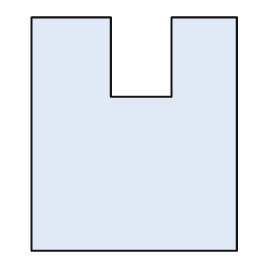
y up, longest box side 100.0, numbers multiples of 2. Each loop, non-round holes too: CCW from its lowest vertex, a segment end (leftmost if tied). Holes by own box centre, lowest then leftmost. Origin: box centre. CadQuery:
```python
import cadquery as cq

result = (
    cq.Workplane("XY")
    .moveTo(-44.0, -50.0)
    .lineTo(44.0, -50.0)
    .lineTo(44.0, 50.0)
    .lineTo(16.0, 50.0)
    .lineTo(16.0, 16.0)
    .lineTo(-10.0, 16.0)
    .lineTo(-10.0, 50.0)
    .lineTo(-44.0, 50.0)
    .close()
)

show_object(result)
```